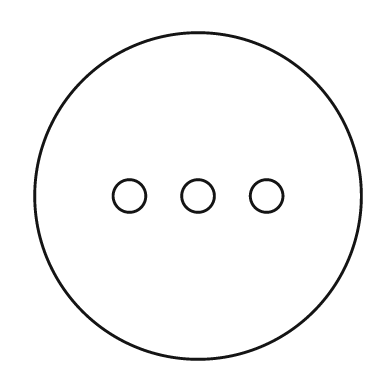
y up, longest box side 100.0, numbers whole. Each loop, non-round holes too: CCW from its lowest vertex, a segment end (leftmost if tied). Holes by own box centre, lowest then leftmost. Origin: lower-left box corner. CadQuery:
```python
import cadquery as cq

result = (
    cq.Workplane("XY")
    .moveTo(50.0, 50.0)
    .circle(50.0)
    .moveTo(29.0, 50.0)
    .circle(5.0)
    .moveTo(50.0, 50.0)
    .circle(5.0)
    .moveTo(71.0, 50.0)
    .circle(5.0)
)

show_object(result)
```